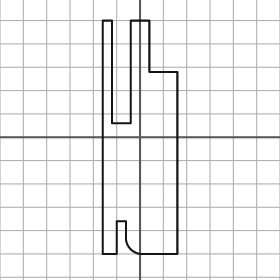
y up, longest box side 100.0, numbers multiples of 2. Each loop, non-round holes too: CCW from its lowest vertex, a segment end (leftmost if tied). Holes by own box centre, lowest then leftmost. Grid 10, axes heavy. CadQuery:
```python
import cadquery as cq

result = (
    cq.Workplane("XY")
    .moveTo(-16.0, -50.0)
    .lineTo(-10.0, -50.0)
    .lineTo(-10.0, -36.0)
    .lineTo(-6.0, -36.0)
    .lineTo(-6.0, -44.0)
    .threePointArc((-4.0, -48.0), (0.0, -50.0))
    .lineTo(16.0, -50.0)
    .lineTo(16.0, 28.0)
    .lineTo(4.0, 28.0)
    .lineTo(4.0, 50.0)
    .lineTo(-4.0, 50.0)
    .lineTo(-4.0, 6.0)
    .lineTo(-12.0, 6.0)
    .lineTo(-12.0, 50.0)
    .lineTo(-16.0, 50.0)
    .close()
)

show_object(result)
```